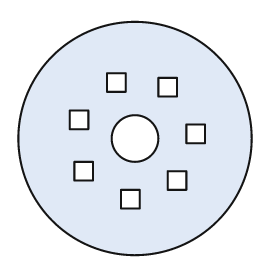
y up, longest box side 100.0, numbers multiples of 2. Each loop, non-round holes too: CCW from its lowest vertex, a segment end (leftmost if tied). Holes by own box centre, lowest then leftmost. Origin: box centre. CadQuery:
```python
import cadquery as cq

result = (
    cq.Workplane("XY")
    .moveTo(0.0, 0.0)
    .circle(50.0)
    .moveTo(-6.0, -30.0)
    .lineTo(2.0, -30.0)
    .lineTo(2.0, -22.0)
    .lineTo(-6.0, -22.0)
    .close()
    .moveTo(14.0, -22.0)
    .lineTo(22.0, -22.0)
    .lineTo(22.0, -14.0)
    .lineTo(14.0, -14.0)
    .close()
    .moveTo(-26.0, -18.0)
    .lineTo(-18.0, -18.0)
    .lineTo(-18.0, -10.0)
    .lineTo(-26.0, -10.0)
    .close()
    .moveTo(0.0, 0.0)
    .circle(10.0)
    .moveTo(22.0, -2.0)
    .lineTo(30.0, -2.0)
    .lineTo(30.0, 6.0)
    .lineTo(22.0, 6.0)
    .close()
    .moveTo(-28.0, 4.0)
    .lineTo(-20.0, 4.0)
    .lineTo(-20.0, 12.0)
    .lineTo(-28.0, 12.0)
    .close()
    .moveTo(10.0, 18.0)
    .lineTo(18.0, 18.0)
    .lineTo(18.0, 26.0)
    .lineTo(10.0, 26.0)
    .close()
    .moveTo(-12.0, 20.0)
    .lineTo(-4.0, 20.0)
    .lineTo(-4.0, 28.0)
    .lineTo(-12.0, 28.0)
    .close()
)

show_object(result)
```